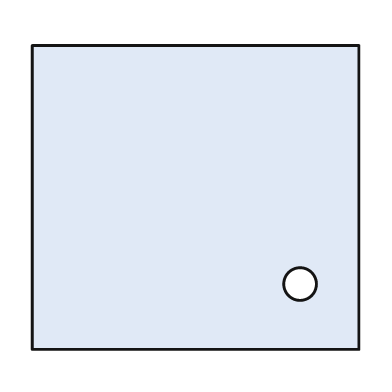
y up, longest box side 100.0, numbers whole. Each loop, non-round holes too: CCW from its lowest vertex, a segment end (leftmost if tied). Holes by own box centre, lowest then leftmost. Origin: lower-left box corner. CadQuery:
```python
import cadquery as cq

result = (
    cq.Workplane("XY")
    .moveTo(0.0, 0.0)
    .lineTo(100.0, 0.0)
    .lineTo(100.0, 93.0)
    .lineTo(0.0, 93.0)
    .close()
    .moveTo(82.0, 20.0)
    .circle(5.0)
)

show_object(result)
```